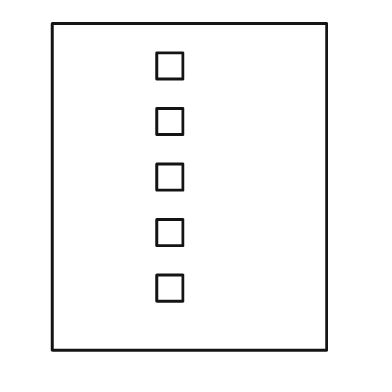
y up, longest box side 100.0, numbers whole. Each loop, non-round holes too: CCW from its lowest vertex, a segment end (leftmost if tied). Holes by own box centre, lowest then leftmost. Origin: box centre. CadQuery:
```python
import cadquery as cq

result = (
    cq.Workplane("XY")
    .moveTo(-42.0, -50.0)
    .lineTo(42.0, -50.0)
    .lineTo(42.0, 50.0)
    .lineTo(-42.0, 50.0)
    .close()
    .moveTo(-10.0, -35.0)
    .lineTo(-2.0, -35.0)
    .lineTo(-2.0, -27.0)
    .lineTo(-10.0, -27.0)
    .close()
    .moveTo(-10.0, -18.0)
    .lineTo(-2.0, -18.0)
    .lineTo(-2.0, -10.0)
    .lineTo(-10.0, -10.0)
    .close()
    .moveTo(-10.0, -1.0)
    .lineTo(-2.0, -1.0)
    .lineTo(-2.0, 7.0)
    .lineTo(-10.0, 7.0)
    .close()
    .moveTo(-10.0, 16.0)
    .lineTo(-2.0, 16.0)
    .lineTo(-2.0, 24.0)
    .lineTo(-10.0, 24.0)
    .close()
    .moveTo(-10.0, 33.0)
    .lineTo(-2.0, 33.0)
    .lineTo(-2.0, 41.0)
    .lineTo(-10.0, 41.0)
    .close()
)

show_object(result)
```